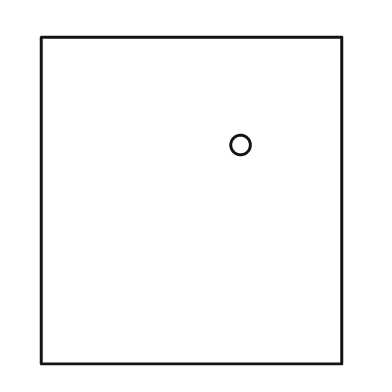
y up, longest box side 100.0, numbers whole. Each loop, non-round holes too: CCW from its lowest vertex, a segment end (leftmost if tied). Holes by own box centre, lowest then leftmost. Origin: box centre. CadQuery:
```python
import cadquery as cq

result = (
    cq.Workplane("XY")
    .moveTo(-46.0, -50.0)
    .lineTo(46.0, -50.0)
    .lineTo(46.0, 50.0)
    .lineTo(-46.0, 50.0)
    .close()
    .moveTo(15.0, 17.0)
    .circle(3.0)
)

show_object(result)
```